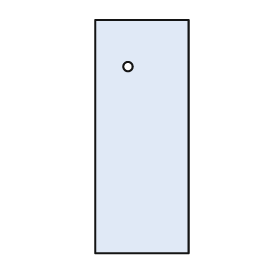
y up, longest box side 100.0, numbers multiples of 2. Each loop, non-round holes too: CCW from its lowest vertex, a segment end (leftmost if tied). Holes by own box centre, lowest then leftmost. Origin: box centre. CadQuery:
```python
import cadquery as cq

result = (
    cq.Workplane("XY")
    .moveTo(-20.0, -50.0)
    .lineTo(20.0, -50.0)
    .lineTo(20.0, 50.0)
    .lineTo(-20.0, 50.0)
    .close()
    .moveTo(-6.0, 30.0)
    .circle(2.0)
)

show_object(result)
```